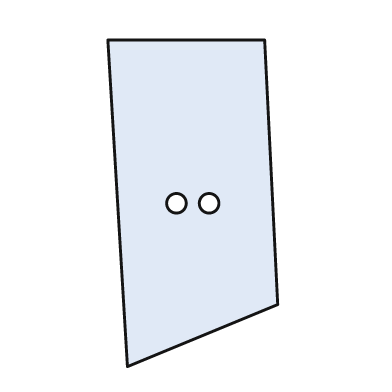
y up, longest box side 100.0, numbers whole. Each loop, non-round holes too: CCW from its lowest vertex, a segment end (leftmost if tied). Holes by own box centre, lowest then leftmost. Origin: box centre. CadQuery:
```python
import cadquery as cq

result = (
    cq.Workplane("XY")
    .moveTo(-20.0, -50.0)
    .lineTo(26.0, -31.0)
    .lineTo(22.0, 50.0)
    .lineTo(-26.0, 50.0)
    .close()
    .moveTo(-5.0, 0.0)
    .circle(3.0)
    .moveTo(5.0, 0.0)
    .circle(3.0)
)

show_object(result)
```